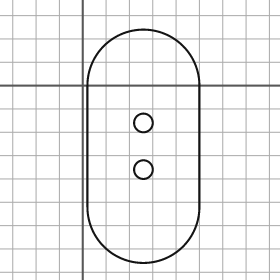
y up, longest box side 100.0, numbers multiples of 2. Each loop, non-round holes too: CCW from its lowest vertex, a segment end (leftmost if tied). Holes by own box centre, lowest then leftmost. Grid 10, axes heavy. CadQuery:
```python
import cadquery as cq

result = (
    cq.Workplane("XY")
    .moveTo(2.0, -52.0)
    .threePointArc((26.0, -76.0), (50.0, -52.0))
    .lineTo(50.0, 0.0)
    .threePointArc((26.0, 24.0), (2.0, 0.0))
    .close()
    .moveTo(26.0, -36.0)
    .circle(4.0)
    .moveTo(26.0, -16.0)
    .circle(4.0)
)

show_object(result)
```